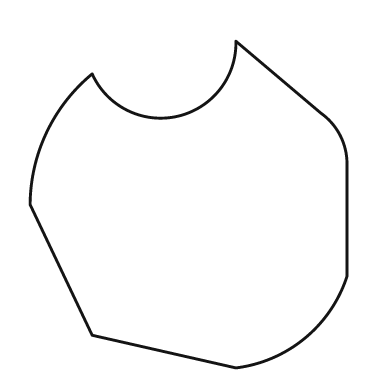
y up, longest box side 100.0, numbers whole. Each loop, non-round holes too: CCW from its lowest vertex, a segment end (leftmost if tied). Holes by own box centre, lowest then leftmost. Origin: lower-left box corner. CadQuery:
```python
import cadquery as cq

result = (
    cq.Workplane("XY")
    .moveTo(63.0, 0.0)
    .threePointArc((84.0, 9.0), (97.0, 28.0))
    .lineTo(97.0, 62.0)
    .threePointArc((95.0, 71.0), (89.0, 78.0))
    .lineTo(63.0, 100.0)
    .threePointArc((45.0, 77.0), (19.0, 90.0))
    .threePointArc((5.0, 72.0), (0.0, 50.0))
    .lineTo(19.0, 10.0)
    .close()
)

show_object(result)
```